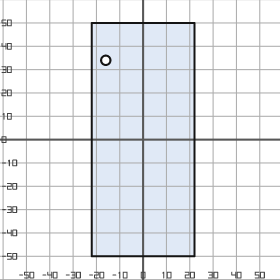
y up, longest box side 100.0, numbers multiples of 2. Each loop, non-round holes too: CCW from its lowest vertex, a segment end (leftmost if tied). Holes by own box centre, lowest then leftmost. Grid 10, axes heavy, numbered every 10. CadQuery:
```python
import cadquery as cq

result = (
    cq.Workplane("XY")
    .moveTo(-22.0, -50.0)
    .lineTo(22.0, -50.0)
    .lineTo(22.0, 50.0)
    .lineTo(-22.0, 50.0)
    .close()
    .moveTo(-16.0, 34.0)
    .circle(2.0)
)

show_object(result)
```